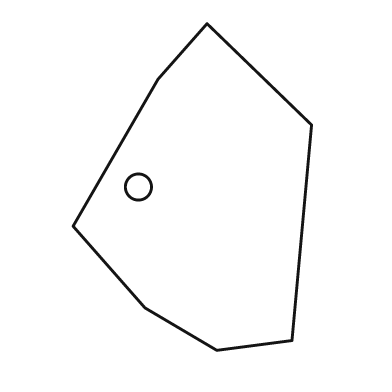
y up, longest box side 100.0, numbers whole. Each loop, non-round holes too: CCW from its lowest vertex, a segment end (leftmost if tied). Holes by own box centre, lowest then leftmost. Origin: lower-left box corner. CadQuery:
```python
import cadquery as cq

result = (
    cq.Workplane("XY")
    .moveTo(44.0, 0.0)
    .lineTo(67.0, 3.0)
    .lineTo(73.0, 69.0)
    .lineTo(41.0, 100.0)
    .lineTo(26.0, 83.0)
    .lineTo(0.0, 38.0)
    .lineTo(22.0, 13.0)
    .close()
    .moveTo(20.0, 50.0)
    .circle(4.0)
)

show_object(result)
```